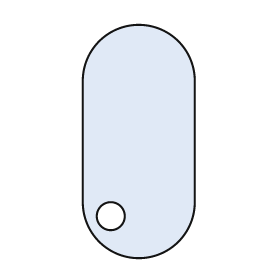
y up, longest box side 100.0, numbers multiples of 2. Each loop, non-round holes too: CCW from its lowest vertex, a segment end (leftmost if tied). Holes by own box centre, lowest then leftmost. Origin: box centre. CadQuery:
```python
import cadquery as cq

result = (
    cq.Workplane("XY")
    .moveTo(-24.0, -26.0)
    .threePointArc((0.0, -50.0), (24.0, -26.0))
    .lineTo(24.0, 26.0)
    .threePointArc((0.0, 50.0), (-24.0, 26.0))
    .close()
    .moveTo(-12.0, -32.0)
    .circle(6.0)
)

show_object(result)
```